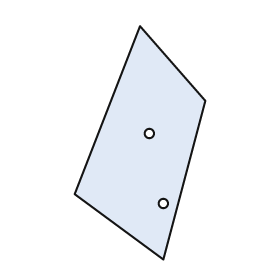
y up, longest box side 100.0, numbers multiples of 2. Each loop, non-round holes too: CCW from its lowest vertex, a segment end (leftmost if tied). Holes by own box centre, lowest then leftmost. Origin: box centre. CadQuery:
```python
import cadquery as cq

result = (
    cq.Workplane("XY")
    .moveTo(10.0, -50.0)
    .lineTo(28.0, 18.0)
    .lineTo(0.0, 50.0)
    .lineTo(-28.0, -22.0)
    .close()
    .moveTo(10.0, -26.0)
    .circle(2.0)
    .moveTo(4.0, 4.0)
    .circle(2.0)
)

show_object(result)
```